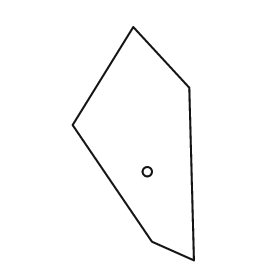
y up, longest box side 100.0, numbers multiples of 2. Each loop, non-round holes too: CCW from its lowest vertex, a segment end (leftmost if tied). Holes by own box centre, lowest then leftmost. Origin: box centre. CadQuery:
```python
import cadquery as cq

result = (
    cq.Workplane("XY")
    .moveTo(26.0, -50.0)
    .lineTo(24.0, 24.0)
    .lineTo(0.0, 50.0)
    .lineTo(-26.0, 8.0)
    .lineTo(8.0, -42.0)
    .close()
    .moveTo(6.0, -12.0)
    .circle(2.0)
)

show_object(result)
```